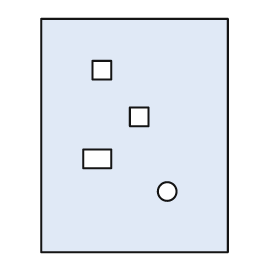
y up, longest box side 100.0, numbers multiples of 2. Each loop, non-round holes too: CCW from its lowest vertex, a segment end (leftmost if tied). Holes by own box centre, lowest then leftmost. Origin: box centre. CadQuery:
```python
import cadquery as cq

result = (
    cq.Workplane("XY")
    .moveTo(-40.0, -50.0)
    .lineTo(40.0, -50.0)
    .lineTo(40.0, 50.0)
    .lineTo(-40.0, 50.0)
    .close()
    .moveTo(14.0, -24.0)
    .circle(4.0)
    .moveTo(-22.0, -14.0)
    .lineTo(-10.0, -14.0)
    .lineTo(-10.0, -6.0)
    .lineTo(-22.0, -6.0)
    .close()
    .moveTo(-2.0, 4.0)
    .lineTo(6.0, 4.0)
    .lineTo(6.0, 12.0)
    .lineTo(-2.0, 12.0)
    .close()
    .moveTo(-18.0, 24.0)
    .lineTo(-10.0, 24.0)
    .lineTo(-10.0, 32.0)
    .lineTo(-18.0, 32.0)
    .close()
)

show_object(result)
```